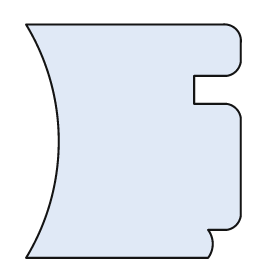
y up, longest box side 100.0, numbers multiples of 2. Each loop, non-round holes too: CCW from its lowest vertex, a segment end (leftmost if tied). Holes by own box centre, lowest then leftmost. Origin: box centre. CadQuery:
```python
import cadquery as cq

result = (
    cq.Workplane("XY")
    .moveTo(-46.0, -50.0)
    .lineTo(32.0, -50.0)
    .threePointArc((34.0, -44.0), (32.0, -38.0))
    .lineTo(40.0, -38.0)
    .threePointArc((44.0, -36.0), (46.0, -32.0))
    .lineTo(46.0, 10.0)
    .threePointArc((44.0, 14.0), (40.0, 16.0))
    .lineTo(26.0, 16.0)
    .lineTo(26.0, 28.0)
    .lineTo(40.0, 28.0)
    .threePointArc((44.0, 30.0), (46.0, 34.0))
    .lineTo(46.0, 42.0)
    .threePointArc((44.0, 48.0), (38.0, 50.0))
    .lineTo(-46.0, 50.0)
    .threePointArc((-32.0, 0.0), (-46.0, -50.0))
    .close()
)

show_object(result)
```